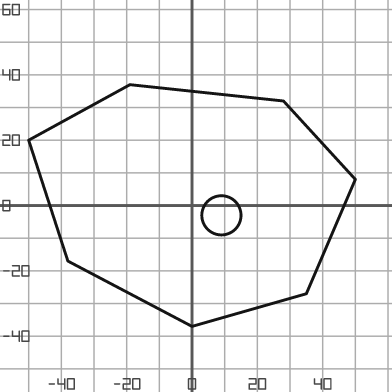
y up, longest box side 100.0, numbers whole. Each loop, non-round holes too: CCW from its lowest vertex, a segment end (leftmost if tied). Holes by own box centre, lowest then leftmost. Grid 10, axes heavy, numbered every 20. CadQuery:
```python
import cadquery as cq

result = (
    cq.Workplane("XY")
    .moveTo(0.0, -37.0)
    .lineTo(35.0, -27.0)
    .lineTo(50.0, 8.0)
    .lineTo(28.0, 32.0)
    .lineTo(-19.0, 37.0)
    .lineTo(-50.0, 20.0)
    .lineTo(-38.0, -17.0)
    .close()
    .moveTo(9.0, -3.0)
    .circle(6.0)
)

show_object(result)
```